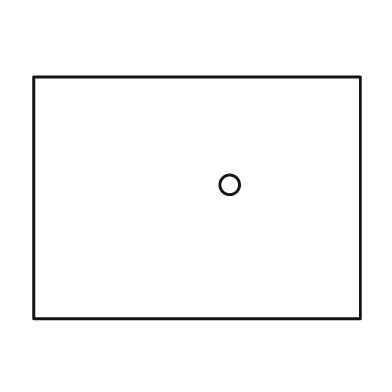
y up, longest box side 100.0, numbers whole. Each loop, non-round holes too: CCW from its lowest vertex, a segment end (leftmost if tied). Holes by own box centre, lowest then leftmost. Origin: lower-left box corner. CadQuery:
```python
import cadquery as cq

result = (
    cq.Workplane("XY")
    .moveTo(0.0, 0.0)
    .lineTo(100.0, 0.0)
    .lineTo(100.0, 74.0)
    .lineTo(0.0, 74.0)
    .close()
    .moveTo(60.0, 41.0)
    .circle(3.0)
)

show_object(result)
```